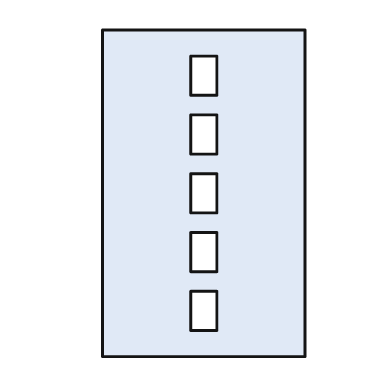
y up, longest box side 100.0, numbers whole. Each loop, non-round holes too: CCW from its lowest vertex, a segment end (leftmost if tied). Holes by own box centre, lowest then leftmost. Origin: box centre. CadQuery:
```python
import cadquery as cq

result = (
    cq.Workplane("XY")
    .moveTo(-31.0, -50.0)
    .lineTo(31.0, -50.0)
    .lineTo(31.0, 50.0)
    .lineTo(-31.0, 50.0)
    .close()
    .moveTo(-4.0, -42.0)
    .lineTo(4.0, -42.0)
    .lineTo(4.0, -30.0)
    .lineTo(-4.0, -30.0)
    .close()
    .moveTo(-4.0, -24.0)
    .lineTo(4.0, -24.0)
    .lineTo(4.0, -12.0)
    .lineTo(-4.0, -12.0)
    .close()
    .moveTo(-4.0, -6.0)
    .lineTo(4.0, -6.0)
    .lineTo(4.0, 6.0)
    .lineTo(-4.0, 6.0)
    .close()
    .moveTo(-4.0, 12.0)
    .lineTo(4.0, 12.0)
    .lineTo(4.0, 24.0)
    .lineTo(-4.0, 24.0)
    .close()
    .moveTo(-4.0, 30.0)
    .lineTo(4.0, 30.0)
    .lineTo(4.0, 42.0)
    .lineTo(-4.0, 42.0)
    .close()
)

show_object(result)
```